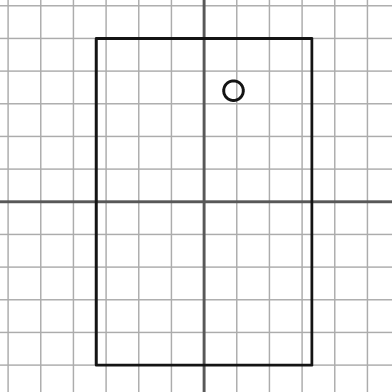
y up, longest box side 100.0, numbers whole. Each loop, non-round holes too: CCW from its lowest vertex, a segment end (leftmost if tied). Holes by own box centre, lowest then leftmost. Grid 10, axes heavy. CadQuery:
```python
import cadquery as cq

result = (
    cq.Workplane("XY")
    .moveTo(-33.0, -50.0)
    .lineTo(33.0, -50.0)
    .lineTo(33.0, 50.0)
    .lineTo(-33.0, 50.0)
    .close()
    .moveTo(9.0, 34.0)
    .circle(3.0)
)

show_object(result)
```